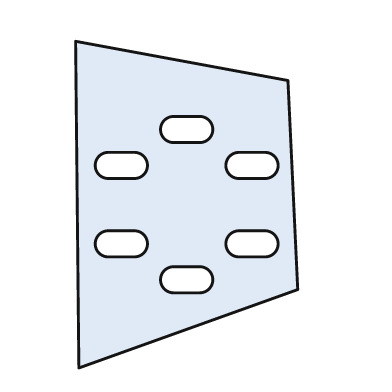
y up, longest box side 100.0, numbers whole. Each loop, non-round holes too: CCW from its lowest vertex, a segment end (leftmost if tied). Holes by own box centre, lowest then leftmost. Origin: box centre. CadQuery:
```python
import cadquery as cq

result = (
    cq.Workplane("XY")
    .moveTo(-33.0, -50.0)
    .lineTo(34.0, -26.0)
    .lineTo(31.0, 38.0)
    .lineTo(-34.0, 50.0)
    .close()
    .moveTo(-4.0, -27.0)
    .lineTo(4.0, -27.0)
    .threePointArc((8.0, -23.0), (4.0, -19.0))
    .lineTo(-4.0, -19.0)
    .threePointArc((-8.0, -23.0), (-4.0, -27.0))
    .close()
    .moveTo(-24.0, -16.0)
    .lineTo(-16.0, -16.0)
    .threePointArc((-12.0, -12.0), (-16.0, -8.0))
    .lineTo(-24.0, -8.0)
    .threePointArc((-28.0, -12.0), (-24.0, -16.0))
    .close()
    .moveTo(16.0, -16.0)
    .lineTo(24.0, -16.0)
    .threePointArc((28.0, -12.0), (24.0, -8.0))
    .lineTo(16.0, -8.0)
    .threePointArc((12.0, -12.0), (16.0, -16.0))
    .close()
    .moveTo(-24.0, 8.0)
    .lineTo(-16.0, 8.0)
    .threePointArc((-12.0, 12.0), (-16.0, 16.0))
    .lineTo(-24.0, 16.0)
    .threePointArc((-28.0, 12.0), (-24.0, 8.0))
    .close()
    .moveTo(16.0, 8.0)
    .lineTo(24.0, 8.0)
    .threePointArc((28.0, 12.0), (24.0, 16.0))
    .lineTo(16.0, 16.0)
    .threePointArc((12.0, 12.0), (16.0, 8.0))
    .close()
    .moveTo(-4.0, 19.0)
    .lineTo(4.0, 19.0)
    .threePointArc((8.0, 23.0), (4.0, 27.0))
    .lineTo(-4.0, 27.0)
    .threePointArc((-8.0, 23.0), (-4.0, 19.0))
    .close()
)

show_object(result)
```